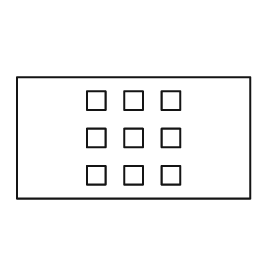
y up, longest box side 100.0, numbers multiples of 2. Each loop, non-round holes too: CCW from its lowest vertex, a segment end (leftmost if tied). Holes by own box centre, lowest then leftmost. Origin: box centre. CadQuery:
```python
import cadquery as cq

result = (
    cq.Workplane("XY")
    .moveTo(-50.0, -26.0)
    .lineTo(50.0, -26.0)
    .lineTo(50.0, 26.0)
    .lineTo(-50.0, 26.0)
    .close()
    .moveTo(-20.0, -20.0)
    .lineTo(-12.0, -20.0)
    .lineTo(-12.0, -12.0)
    .lineTo(-20.0, -12.0)
    .close()
    .moveTo(-4.0, -20.0)
    .lineTo(4.0, -20.0)
    .lineTo(4.0, -12.0)
    .lineTo(-4.0, -12.0)
    .close()
    .moveTo(12.0, -20.0)
    .lineTo(20.0, -20.0)
    .lineTo(20.0, -12.0)
    .lineTo(12.0, -12.0)
    .close()
    .moveTo(-20.0, -4.0)
    .lineTo(-12.0, -4.0)
    .lineTo(-12.0, 4.0)
    .lineTo(-20.0, 4.0)
    .close()
    .moveTo(-4.0, -4.0)
    .lineTo(4.0, -4.0)
    .lineTo(4.0, 4.0)
    .lineTo(-4.0, 4.0)
    .close()
    .moveTo(12.0, -4.0)
    .lineTo(20.0, -4.0)
    .lineTo(20.0, 4.0)
    .lineTo(12.0, 4.0)
    .close()
    .moveTo(-20.0, 12.0)
    .lineTo(-12.0, 12.0)
    .lineTo(-12.0, 20.0)
    .lineTo(-20.0, 20.0)
    .close()
    .moveTo(-4.0, 12.0)
    .lineTo(4.0, 12.0)
    .lineTo(4.0, 20.0)
    .lineTo(-4.0, 20.0)
    .close()
    .moveTo(12.0, 12.0)
    .lineTo(20.0, 12.0)
    .lineTo(20.0, 20.0)
    .lineTo(12.0, 20.0)
    .close()
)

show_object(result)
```